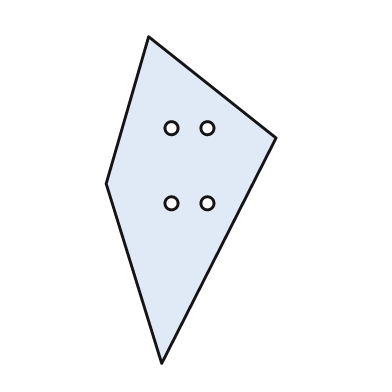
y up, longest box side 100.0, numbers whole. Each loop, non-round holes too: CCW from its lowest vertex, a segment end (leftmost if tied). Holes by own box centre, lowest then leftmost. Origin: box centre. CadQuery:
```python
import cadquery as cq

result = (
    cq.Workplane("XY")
    .moveTo(-9.0, -50.0)
    .lineTo(26.0, 19.0)
    .lineTo(-13.0, 50.0)
    .lineTo(-26.0, 5.0)
    .close()
    .moveTo(-6.0, -1.0)
    .circle(2.0)
    .moveTo(5.0, -1.0)
    .circle(2.0)
    .moveTo(-6.0, 22.0)
    .circle(2.0)
    .moveTo(5.0, 22.0)
    .circle(2.0)
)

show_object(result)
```